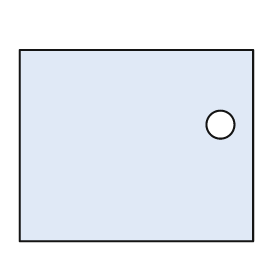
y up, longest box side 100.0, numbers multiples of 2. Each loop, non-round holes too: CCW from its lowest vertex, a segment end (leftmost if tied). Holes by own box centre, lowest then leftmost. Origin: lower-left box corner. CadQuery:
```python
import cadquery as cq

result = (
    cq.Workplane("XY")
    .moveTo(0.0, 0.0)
    .lineTo(100.0, 0.0)
    .lineTo(100.0, 82.0)
    .lineTo(0.0, 82.0)
    .close()
    .moveTo(86.0, 50.0)
    .circle(6.0)
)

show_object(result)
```